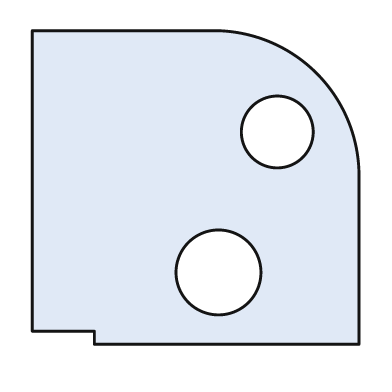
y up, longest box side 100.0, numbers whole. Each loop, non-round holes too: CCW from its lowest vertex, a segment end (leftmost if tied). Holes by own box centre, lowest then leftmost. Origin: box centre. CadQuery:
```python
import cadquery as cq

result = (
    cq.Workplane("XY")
    .moveTo(-31.0, -48.0)
    .lineTo(50.0, -48.0)
    .lineTo(50.0, 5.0)
    .threePointArc((37.0, 35.0), (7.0, 48.0))
    .lineTo(-50.0, 48.0)
    .lineTo(-50.0, -44.0)
    .lineTo(-31.0, -44.0)
    .close()
    .moveTo(7.0, -26.0)
    .circle(13.0)
    .moveTo(25.0, 17.0)
    .circle(11.0)
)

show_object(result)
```